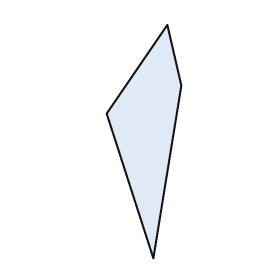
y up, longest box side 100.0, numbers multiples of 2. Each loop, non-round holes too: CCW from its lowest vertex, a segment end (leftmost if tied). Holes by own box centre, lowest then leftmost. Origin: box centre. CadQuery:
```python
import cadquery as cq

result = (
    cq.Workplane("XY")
    .moveTo(4.0, -50.0)
    .lineTo(16.0, 24.0)
    .lineTo(10.0, 50.0)
    .lineTo(-16.0, 12.0)
    .close()
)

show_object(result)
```